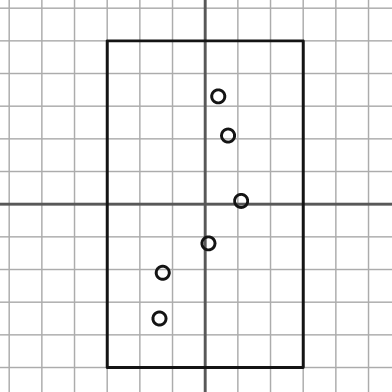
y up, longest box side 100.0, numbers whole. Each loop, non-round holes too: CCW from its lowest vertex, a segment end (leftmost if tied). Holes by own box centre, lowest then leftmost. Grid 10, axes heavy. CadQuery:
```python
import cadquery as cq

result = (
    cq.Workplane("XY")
    .moveTo(-30.0, -50.0)
    .lineTo(30.0, -50.0)
    .lineTo(30.0, 50.0)
    .lineTo(-30.0, 50.0)
    .close()
    .moveTo(-14.0, -35.0)
    .circle(2.0)
    .moveTo(-13.0, -21.0)
    .circle(2.0)
    .moveTo(1.0, -12.0)
    .circle(2.0)
    .moveTo(11.0, 1.0)
    .circle(2.0)
    .moveTo(7.0, 21.0)
    .circle(2.0)
    .moveTo(4.0, 33.0)
    .circle(2.0)
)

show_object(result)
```